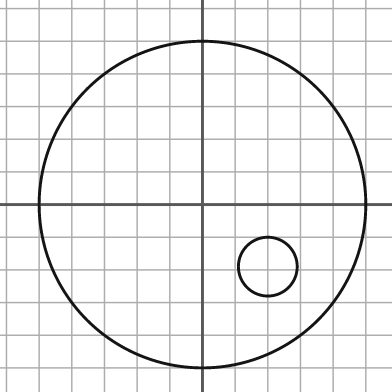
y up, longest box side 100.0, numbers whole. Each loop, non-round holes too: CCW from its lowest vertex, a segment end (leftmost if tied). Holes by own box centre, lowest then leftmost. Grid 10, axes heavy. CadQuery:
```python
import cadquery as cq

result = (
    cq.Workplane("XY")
    .moveTo(0.0, 0.0)
    .circle(50.0)
    .moveTo(20.0, -19.0)
    .circle(9.0)
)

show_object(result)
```